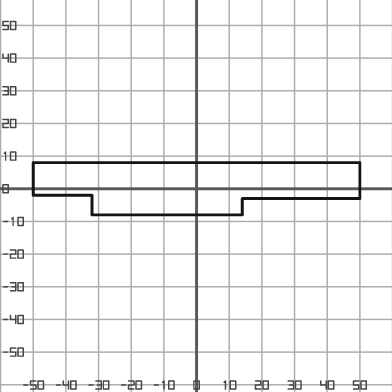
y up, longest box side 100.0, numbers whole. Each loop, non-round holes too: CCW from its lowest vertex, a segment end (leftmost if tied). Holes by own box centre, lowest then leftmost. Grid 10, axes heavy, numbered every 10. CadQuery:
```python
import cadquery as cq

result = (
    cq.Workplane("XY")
    .moveTo(-32.0, -8.0)
    .lineTo(14.0, -8.0)
    .lineTo(14.0, -3.0)
    .lineTo(50.0, -3.0)
    .lineTo(50.0, 8.0)
    .lineTo(-50.0, 8.0)
    .lineTo(-50.0, -2.0)
    .lineTo(-32.0, -2.0)
    .close()
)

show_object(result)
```